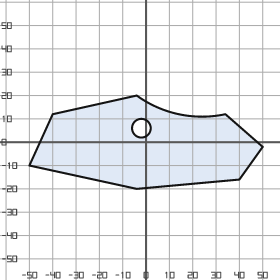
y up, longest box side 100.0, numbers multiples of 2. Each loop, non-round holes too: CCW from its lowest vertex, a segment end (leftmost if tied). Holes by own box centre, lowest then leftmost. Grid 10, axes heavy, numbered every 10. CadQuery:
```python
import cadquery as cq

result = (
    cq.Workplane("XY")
    .moveTo(-4.0, -20.0)
    .lineTo(40.0, -16.0)
    .lineTo(50.0, -2.0)
    .lineTo(34.0, 12.0)
    .threePointArc((14.0, 12.0), (-4.0, 20.0))
    .lineTo(-40.0, 12.0)
    .lineTo(-50.0, -10.0)
    .close()
    .moveTo(-2.0, 6.0)
    .circle(4.0)
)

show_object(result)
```